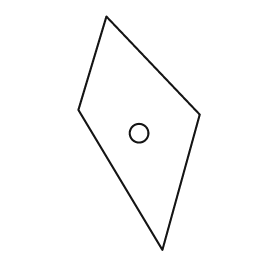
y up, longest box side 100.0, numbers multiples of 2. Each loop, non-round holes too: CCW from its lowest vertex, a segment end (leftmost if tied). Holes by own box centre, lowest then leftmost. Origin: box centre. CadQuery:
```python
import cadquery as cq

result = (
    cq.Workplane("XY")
    .moveTo(10.0, -50.0)
    .lineTo(26.0, 8.0)
    .lineTo(-14.0, 50.0)
    .lineTo(-26.0, 10.0)
    .close()
    .moveTo(0.0, 0.0)
    .circle(4.0)
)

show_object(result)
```